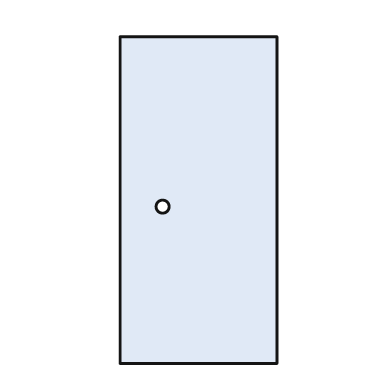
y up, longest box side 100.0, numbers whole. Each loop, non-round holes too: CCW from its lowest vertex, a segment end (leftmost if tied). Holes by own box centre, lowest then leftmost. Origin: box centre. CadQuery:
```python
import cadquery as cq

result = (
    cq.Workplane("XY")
    .moveTo(-24.0, -50.0)
    .lineTo(24.0, -50.0)
    .lineTo(24.0, 50.0)
    .lineTo(-24.0, 50.0)
    .close()
    .moveTo(-11.0, -2.0)
    .circle(2.0)
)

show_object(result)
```